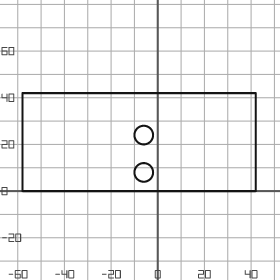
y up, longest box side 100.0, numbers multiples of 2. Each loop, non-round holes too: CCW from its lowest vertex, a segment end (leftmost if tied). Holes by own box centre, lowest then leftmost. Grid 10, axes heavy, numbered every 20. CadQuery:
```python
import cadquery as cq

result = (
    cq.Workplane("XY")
    .moveTo(-58.0, 0.0)
    .lineTo(42.0, 0.0)
    .lineTo(42.0, 42.0)
    .lineTo(-58.0, 42.0)
    .close()
    .moveTo(-6.0, 8.0)
    .circle(4.0)
    .moveTo(-6.0, 24.0)
    .circle(4.0)
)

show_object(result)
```